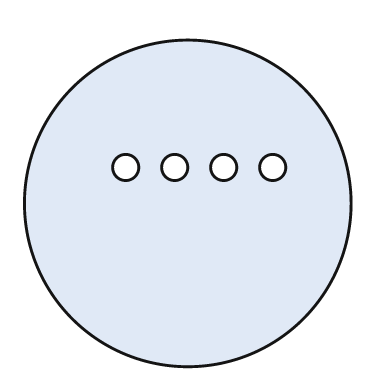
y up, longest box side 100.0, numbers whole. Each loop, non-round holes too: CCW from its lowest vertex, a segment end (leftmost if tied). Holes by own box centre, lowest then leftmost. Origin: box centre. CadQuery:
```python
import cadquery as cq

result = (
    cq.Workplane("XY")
    .moveTo(0.0, 0.0)
    .circle(50.0)
    .moveTo(-19.0, 11.0)
    .circle(4.0)
    .moveTo(-4.0, 11.0)
    .circle(4.0)
    .moveTo(11.0, 11.0)
    .circle(4.0)
    .moveTo(26.0, 11.0)
    .circle(4.0)
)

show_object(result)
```